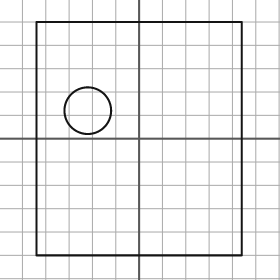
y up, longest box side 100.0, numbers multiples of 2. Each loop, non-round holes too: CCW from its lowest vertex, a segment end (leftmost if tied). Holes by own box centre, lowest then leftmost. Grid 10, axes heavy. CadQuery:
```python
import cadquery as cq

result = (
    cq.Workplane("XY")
    .moveTo(-44.0, -50.0)
    .lineTo(44.0, -50.0)
    .lineTo(44.0, 50.0)
    .lineTo(-44.0, 50.0)
    .close()
    .moveTo(-22.0, 12.0)
    .circle(10.0)
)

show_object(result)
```